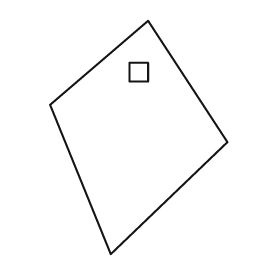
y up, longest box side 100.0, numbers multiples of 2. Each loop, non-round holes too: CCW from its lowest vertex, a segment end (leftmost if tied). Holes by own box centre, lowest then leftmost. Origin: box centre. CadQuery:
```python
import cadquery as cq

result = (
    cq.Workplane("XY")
    .moveTo(-12.0, -50.0)
    .lineTo(38.0, -2.0)
    .lineTo(4.0, 50.0)
    .lineTo(-38.0, 14.0)
    .close()
    .moveTo(-4.0, 24.0)
    .lineTo(4.0, 24.0)
    .lineTo(4.0, 32.0)
    .lineTo(-4.0, 32.0)
    .close()
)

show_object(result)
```